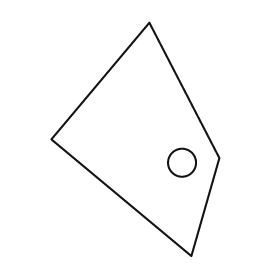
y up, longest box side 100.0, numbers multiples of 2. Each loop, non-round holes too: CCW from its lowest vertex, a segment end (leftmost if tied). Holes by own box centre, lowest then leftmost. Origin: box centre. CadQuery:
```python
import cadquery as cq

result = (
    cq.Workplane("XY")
    .moveTo(24.0, -50.0)
    .lineTo(36.0, -8.0)
    .lineTo(6.0, 50.0)
    .lineTo(-36.0, 0.0)
    .close()
    .moveTo(20.0, -10.0)
    .circle(6.0)
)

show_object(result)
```